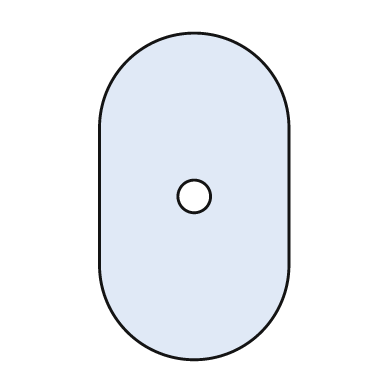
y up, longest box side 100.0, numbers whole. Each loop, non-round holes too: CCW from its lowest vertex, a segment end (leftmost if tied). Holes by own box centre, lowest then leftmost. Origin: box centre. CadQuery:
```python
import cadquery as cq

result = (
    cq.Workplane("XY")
    .moveTo(-29.0, -21.0)
    .threePointArc((0.0, -50.0), (29.0, -21.0))
    .lineTo(29.0, 21.0)
    .threePointArc((0.0, 50.0), (-29.0, 21.0))
    .close()
    .moveTo(0.0, 0.0)
    .circle(5.0)
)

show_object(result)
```